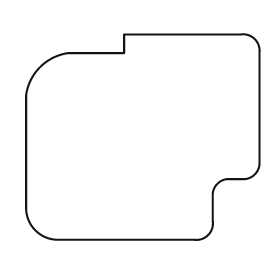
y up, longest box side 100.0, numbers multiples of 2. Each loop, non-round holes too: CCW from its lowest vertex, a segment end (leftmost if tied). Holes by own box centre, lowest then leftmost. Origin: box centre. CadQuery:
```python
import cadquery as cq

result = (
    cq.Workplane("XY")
    .moveTo(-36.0, -44.0)
    .lineTo(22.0, -44.0)
    .threePointArc((28.0, -42.0), (30.0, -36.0))
    .lineTo(30.0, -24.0)
    .threePointArc((32.0, -20.0), (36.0, -18.0))
    .lineTo(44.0, -18.0)
    .threePointArc((48.0, -16.0), (50.0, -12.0))
    .lineTo(50.0, 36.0)
    .threePointArc((48.0, 42.0), (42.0, 44.0))
    .lineTo(-8.0, 44.0)
    .lineTo(-8.0, 36.0)
    .lineTo(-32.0, 36.0)
    .threePointArc((-44.0, 30.0), (-50.0, 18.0))
    .lineTo(-50.0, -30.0)
    .threePointArc((-46.0, -40.0), (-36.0, -44.0))
    .close()
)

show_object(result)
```